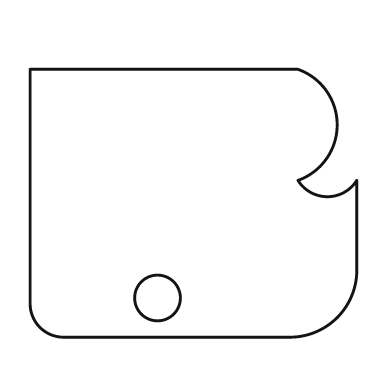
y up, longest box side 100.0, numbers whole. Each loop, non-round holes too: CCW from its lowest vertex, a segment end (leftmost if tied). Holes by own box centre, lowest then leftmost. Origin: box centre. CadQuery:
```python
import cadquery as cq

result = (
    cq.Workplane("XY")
    .moveTo(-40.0, -41.0)
    .lineTo(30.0, -41.0)
    .threePointArc((44.0, -35.0), (50.0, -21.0))
    .lineTo(50.0, 7.0)
    .threePointArc((41.0, 2.0), (32.0, 7.0))
    .threePointArc((44.0, 24.0), (32.0, 41.0))
    .lineTo(-50.0, 41.0)
    .lineTo(-50.0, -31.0)
    .threePointArc((-47.0, -38.0), (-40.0, -41.0))
    .close()
    .moveTo(-11.0, -29.0)
    .circle(7.0)
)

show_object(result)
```